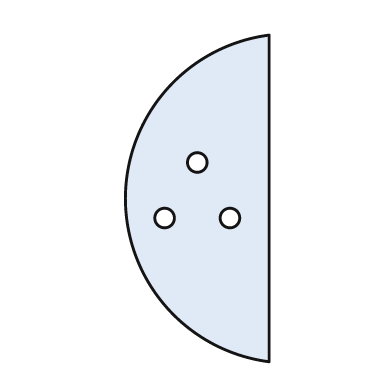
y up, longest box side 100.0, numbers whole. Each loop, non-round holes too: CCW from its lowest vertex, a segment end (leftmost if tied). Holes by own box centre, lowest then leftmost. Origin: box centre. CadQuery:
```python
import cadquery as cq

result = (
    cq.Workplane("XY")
    .moveTo(22.0, -50.0)
    .lineTo(22.0, 50.0)
    .threePointArc((-22.0, 0.0), (22.0, -50.0))
    .close()
    .moveTo(-10.0, -6.0)
    .circle(3.0)
    .moveTo(10.0, -6.0)
    .circle(3.0)
    .moveTo(0.0, 11.0)
    .circle(3.0)
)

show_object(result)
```